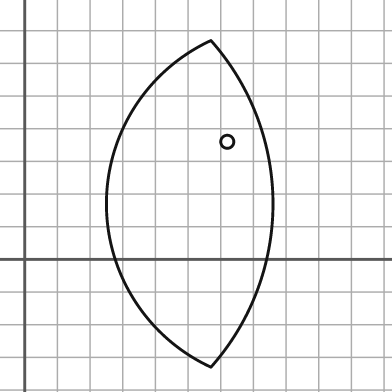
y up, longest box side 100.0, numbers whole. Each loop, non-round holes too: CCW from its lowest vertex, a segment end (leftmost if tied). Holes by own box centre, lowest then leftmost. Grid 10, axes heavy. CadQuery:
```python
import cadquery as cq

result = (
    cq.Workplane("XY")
    .moveTo(57.0, -33.0)
    .threePointArc((76.0, 17.0), (57.0, 67.0))
    .threePointArc((25.0, 17.0), (57.0, -33.0))
    .close()
    .moveTo(62.0, 36.0)
    .circle(2.0)
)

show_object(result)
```